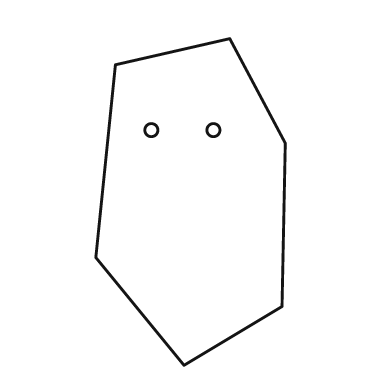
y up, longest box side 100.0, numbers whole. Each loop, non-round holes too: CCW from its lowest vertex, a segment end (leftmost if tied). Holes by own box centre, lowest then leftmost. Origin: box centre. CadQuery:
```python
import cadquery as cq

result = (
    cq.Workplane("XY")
    .moveTo(-2.0, -50.0)
    .lineTo(28.0, -32.0)
    .lineTo(29.0, 18.0)
    .lineTo(12.0, 50.0)
    .lineTo(-23.0, 42.0)
    .lineTo(-29.0, -17.0)
    .close()
    .moveTo(-12.0, 22.0)
    .circle(2.0)
    .moveTo(7.0, 22.0)
    .circle(2.0)
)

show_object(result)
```